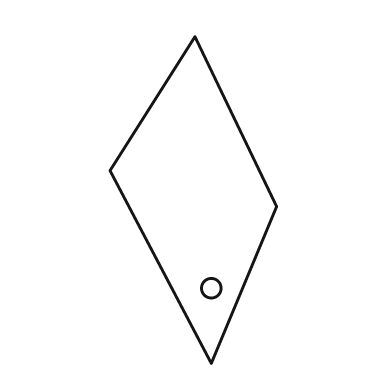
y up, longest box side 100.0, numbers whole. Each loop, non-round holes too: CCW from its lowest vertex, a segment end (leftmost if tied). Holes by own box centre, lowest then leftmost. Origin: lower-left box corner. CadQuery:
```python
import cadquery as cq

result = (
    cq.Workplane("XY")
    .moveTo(31.0, 0.0)
    .lineTo(51.0, 48.0)
    .lineTo(26.0, 100.0)
    .lineTo(0.0, 59.0)
    .close()
    .moveTo(31.0, 23.0)
    .circle(3.0)
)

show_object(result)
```